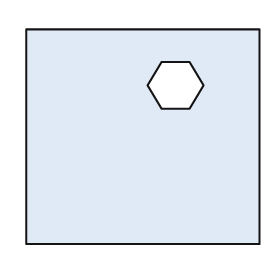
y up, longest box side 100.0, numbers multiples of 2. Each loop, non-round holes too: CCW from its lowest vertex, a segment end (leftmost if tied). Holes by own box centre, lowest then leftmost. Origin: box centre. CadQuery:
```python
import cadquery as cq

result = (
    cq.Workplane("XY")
    .moveTo(-50.0, -46.0)
    .lineTo(50.0, -46.0)
    .lineTo(50.0, 46.0)
    .lineTo(-50.0, 46.0)
    .close()
    .moveTo(8.0, 12.0)
    .lineTo(20.0, 12.0)
    .lineTo(26.0, 22.0)
    .lineTo(20.0, 32.0)
    .lineTo(8.0, 32.0)
    .lineTo(2.0, 22.0)
    .close()
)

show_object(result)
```